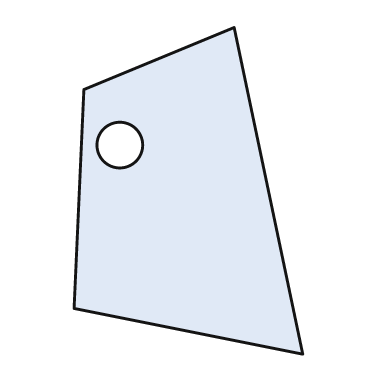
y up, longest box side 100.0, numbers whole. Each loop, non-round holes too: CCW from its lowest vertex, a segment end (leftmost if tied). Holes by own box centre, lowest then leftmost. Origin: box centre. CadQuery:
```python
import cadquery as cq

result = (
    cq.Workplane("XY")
    .moveTo(35.0, -50.0)
    .lineTo(14.0, 50.0)
    .lineTo(-32.0, 31.0)
    .lineTo(-35.0, -36.0)
    .close()
    .moveTo(-21.0, 14.0)
    .circle(7.0)
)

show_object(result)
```